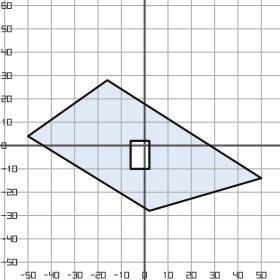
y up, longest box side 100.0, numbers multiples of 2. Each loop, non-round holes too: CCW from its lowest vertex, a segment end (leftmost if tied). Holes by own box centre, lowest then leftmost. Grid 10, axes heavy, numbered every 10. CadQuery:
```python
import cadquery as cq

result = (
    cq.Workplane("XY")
    .moveTo(2.0, -28.0)
    .lineTo(50.0, -14.0)
    .lineTo(-16.0, 28.0)
    .lineTo(-50.0, 4.0)
    .close()
    .moveTo(-6.0, -10.0)
    .lineTo(2.0, -10.0)
    .lineTo(2.0, 2.0)
    .lineTo(-6.0, 2.0)
    .close()
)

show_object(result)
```